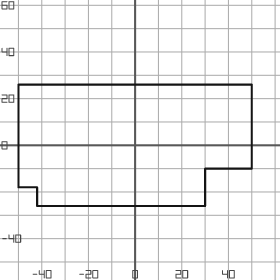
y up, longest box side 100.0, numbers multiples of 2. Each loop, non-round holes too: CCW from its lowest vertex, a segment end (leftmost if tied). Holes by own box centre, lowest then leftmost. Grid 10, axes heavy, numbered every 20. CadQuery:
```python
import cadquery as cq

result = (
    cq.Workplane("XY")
    .moveTo(-42.0, -26.0)
    .lineTo(30.0, -26.0)
    .lineTo(30.0, -10.0)
    .lineTo(50.0, -10.0)
    .lineTo(50.0, 26.0)
    .lineTo(-50.0, 26.0)
    .lineTo(-50.0, -18.0)
    .lineTo(-42.0, -18.0)
    .close()
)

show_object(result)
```